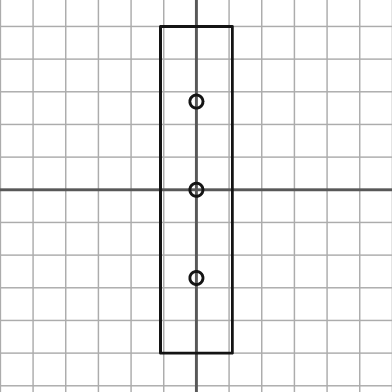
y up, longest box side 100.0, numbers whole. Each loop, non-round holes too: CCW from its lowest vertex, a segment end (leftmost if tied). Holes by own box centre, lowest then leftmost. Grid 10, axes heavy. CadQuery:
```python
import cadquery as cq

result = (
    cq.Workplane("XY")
    .moveTo(-11.0, -50.0)
    .lineTo(11.0, -50.0)
    .lineTo(11.0, 50.0)
    .lineTo(-11.0, 50.0)
    .close()
    .moveTo(0.0, -27.0)
    .circle(2.0)
    .moveTo(0.0, 0.0)
    .circle(2.0)
    .moveTo(0.0, 27.0)
    .circle(2.0)
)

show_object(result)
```